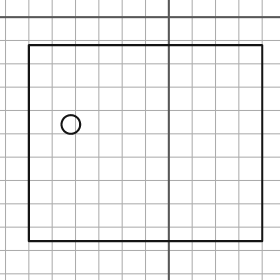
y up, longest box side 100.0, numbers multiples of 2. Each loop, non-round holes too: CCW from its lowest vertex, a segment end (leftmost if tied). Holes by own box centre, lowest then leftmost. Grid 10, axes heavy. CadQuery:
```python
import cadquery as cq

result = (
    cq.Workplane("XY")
    .moveTo(-60.0, -96.0)
    .lineTo(40.0, -96.0)
    .lineTo(40.0, -12.0)
    .lineTo(-60.0, -12.0)
    .close()
    .moveTo(-42.0, -46.0)
    .circle(4.0)
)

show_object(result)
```